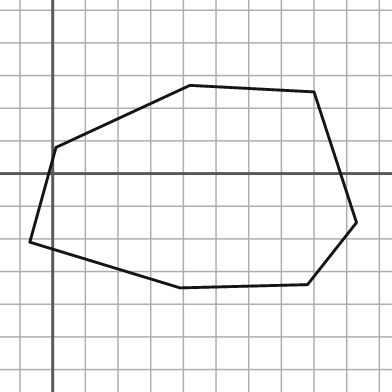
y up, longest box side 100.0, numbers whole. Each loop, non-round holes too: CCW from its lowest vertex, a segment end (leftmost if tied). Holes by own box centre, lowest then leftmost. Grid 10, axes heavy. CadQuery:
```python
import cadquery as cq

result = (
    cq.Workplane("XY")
    .moveTo(39.0, -35.0)
    .lineTo(78.0, -34.0)
    .lineTo(93.0, -15.0)
    .lineTo(80.0, 25.0)
    .lineTo(42.0, 27.0)
    .lineTo(1.0, 8.0)
    .lineTo(-7.0, -21.0)
    .close()
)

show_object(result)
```